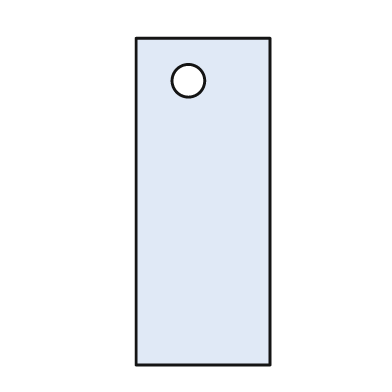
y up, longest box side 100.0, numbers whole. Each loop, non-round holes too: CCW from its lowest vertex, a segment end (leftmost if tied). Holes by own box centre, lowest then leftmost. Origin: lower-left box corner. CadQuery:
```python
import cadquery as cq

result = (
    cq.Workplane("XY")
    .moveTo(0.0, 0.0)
    .lineTo(41.0, 0.0)
    .lineTo(41.0, 100.0)
    .lineTo(0.0, 100.0)
    .close()
    .moveTo(16.0, 87.0)
    .circle(5.0)
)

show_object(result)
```